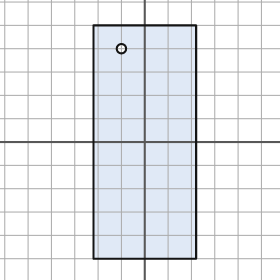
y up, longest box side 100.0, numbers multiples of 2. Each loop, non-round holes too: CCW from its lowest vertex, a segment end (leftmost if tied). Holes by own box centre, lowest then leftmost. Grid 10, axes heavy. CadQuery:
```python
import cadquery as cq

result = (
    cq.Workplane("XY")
    .moveTo(-22.0, -50.0)
    .lineTo(22.0, -50.0)
    .lineTo(22.0, 50.0)
    .lineTo(-22.0, 50.0)
    .close()
    .moveTo(-10.0, 40.0)
    .circle(2.0)
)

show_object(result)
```